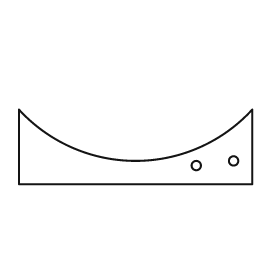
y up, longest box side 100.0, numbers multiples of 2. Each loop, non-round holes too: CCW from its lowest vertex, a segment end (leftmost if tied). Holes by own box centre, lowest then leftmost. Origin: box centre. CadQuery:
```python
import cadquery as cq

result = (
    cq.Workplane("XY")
    .moveTo(-50.0, -16.0)
    .lineTo(50.0, -16.0)
    .lineTo(50.0, 16.0)
    .threePointArc((0.0, -6.0), (-50.0, 16.0))
    .close()
    .moveTo(26.0, -8.0)
    .circle(2.0)
    .moveTo(42.0, -6.0)
    .circle(2.0)
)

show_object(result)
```